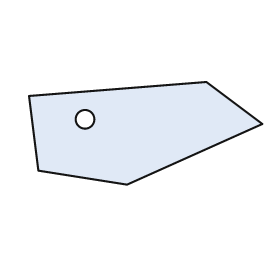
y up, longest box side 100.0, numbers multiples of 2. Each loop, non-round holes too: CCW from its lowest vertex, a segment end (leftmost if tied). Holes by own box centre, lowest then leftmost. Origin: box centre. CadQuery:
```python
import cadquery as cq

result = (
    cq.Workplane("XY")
    .moveTo(-8.0, -22.0)
    .lineTo(50.0, 4.0)
    .lineTo(26.0, 22.0)
    .lineTo(-50.0, 16.0)
    .lineTo(-46.0, -16.0)
    .close()
    .moveTo(-26.0, 6.0)
    .circle(4.0)
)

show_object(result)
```